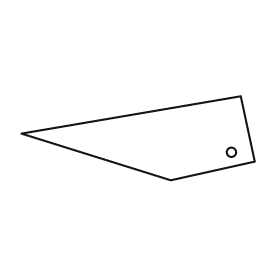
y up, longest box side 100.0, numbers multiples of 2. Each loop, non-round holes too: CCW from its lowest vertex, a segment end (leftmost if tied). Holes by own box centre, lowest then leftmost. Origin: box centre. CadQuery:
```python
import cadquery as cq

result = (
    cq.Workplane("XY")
    .moveTo(14.0, -18.0)
    .lineTo(50.0, -10.0)
    .lineTo(44.0, 18.0)
    .lineTo(-50.0, 2.0)
    .close()
    .moveTo(40.0, -6.0)
    .circle(2.0)
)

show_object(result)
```